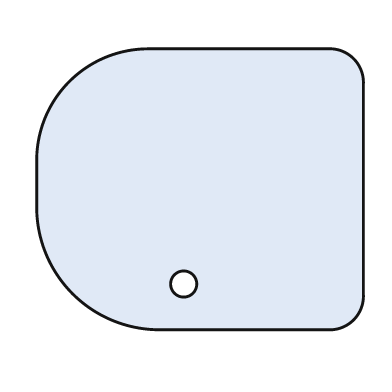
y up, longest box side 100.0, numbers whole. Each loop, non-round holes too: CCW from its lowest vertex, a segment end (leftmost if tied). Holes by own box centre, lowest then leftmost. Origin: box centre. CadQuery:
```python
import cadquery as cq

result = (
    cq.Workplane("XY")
    .moveTo(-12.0, -43.0)
    .lineTo(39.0, -43.0)
    .threePointArc((47.0, -40.0), (50.0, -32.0))
    .lineTo(50.0, 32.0)
    .threePointArc((47.0, 40.0), (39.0, 43.0))
    .lineTo(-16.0, 43.0)
    .threePointArc((-40.0, 33.0), (-50.0, 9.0))
    .lineTo(-50.0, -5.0)
    .threePointArc((-39.0, -32.0), (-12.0, -43.0))
    .close()
    .moveTo(-5.0, -29.0)
    .circle(4.0)
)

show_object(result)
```